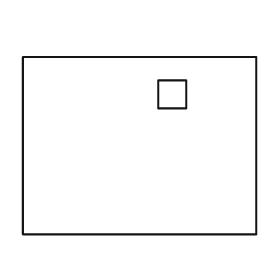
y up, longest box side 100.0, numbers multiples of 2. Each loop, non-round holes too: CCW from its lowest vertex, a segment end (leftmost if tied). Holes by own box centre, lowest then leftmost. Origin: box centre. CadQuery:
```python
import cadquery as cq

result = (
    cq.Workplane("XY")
    .moveTo(-50.0, -38.0)
    .lineTo(50.0, -38.0)
    .lineTo(50.0, 38.0)
    .lineTo(-50.0, 38.0)
    .close()
    .moveTo(8.0, 16.0)
    .lineTo(20.0, 16.0)
    .lineTo(20.0, 28.0)
    .lineTo(8.0, 28.0)
    .close()
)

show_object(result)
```